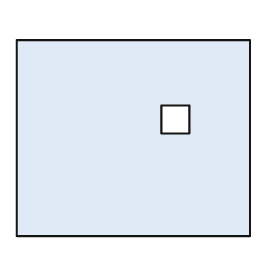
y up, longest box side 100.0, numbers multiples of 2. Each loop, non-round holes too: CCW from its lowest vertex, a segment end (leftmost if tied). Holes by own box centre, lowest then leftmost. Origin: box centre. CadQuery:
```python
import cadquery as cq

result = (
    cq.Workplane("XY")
    .moveTo(-50.0, -42.0)
    .lineTo(50.0, -42.0)
    .lineTo(50.0, 42.0)
    .lineTo(-50.0, 42.0)
    .close()
    .moveTo(12.0, 2.0)
    .lineTo(24.0, 2.0)
    .lineTo(24.0, 14.0)
    .lineTo(12.0, 14.0)
    .close()
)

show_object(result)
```